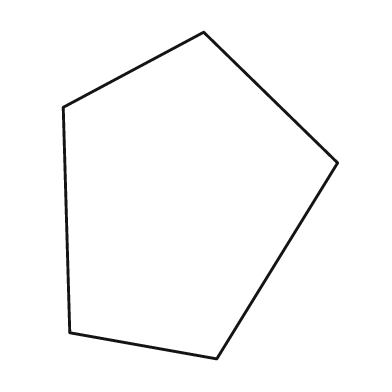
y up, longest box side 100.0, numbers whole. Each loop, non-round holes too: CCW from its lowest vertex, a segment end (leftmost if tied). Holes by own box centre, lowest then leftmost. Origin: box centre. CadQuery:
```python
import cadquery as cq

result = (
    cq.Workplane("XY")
    .moveTo(5.0, -50.0)
    .lineTo(42.0, 10.0)
    .lineTo(1.0, 50.0)
    .lineTo(-42.0, 27.0)
    .lineTo(-40.0, -42.0)
    .close()
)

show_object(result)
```